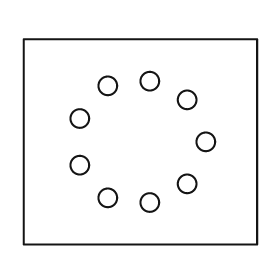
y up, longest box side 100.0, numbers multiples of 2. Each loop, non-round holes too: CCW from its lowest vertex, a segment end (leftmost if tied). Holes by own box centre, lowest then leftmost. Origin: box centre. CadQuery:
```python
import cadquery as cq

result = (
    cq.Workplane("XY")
    .moveTo(-50.0, -44.0)
    .lineTo(50.0, -44.0)
    .lineTo(50.0, 44.0)
    .lineTo(-50.0, 44.0)
    .close()
    .moveTo(4.0, -26.0)
    .circle(4.0)
    .moveTo(-14.0, -24.0)
    .circle(4.0)
    .moveTo(20.0, -18.0)
    .circle(4.0)
    .moveTo(-26.0, -10.0)
    .circle(4.0)
    .moveTo(28.0, 0.0)
    .circle(4.0)
    .moveTo(-26.0, 10.0)
    .circle(4.0)
    .moveTo(20.0, 18.0)
    .circle(4.0)
    .moveTo(-14.0, 24.0)
    .circle(4.0)
    .moveTo(4.0, 26.0)
    .circle(4.0)
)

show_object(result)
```